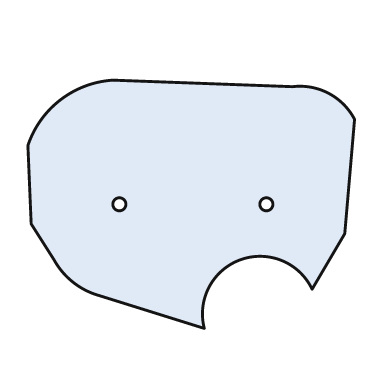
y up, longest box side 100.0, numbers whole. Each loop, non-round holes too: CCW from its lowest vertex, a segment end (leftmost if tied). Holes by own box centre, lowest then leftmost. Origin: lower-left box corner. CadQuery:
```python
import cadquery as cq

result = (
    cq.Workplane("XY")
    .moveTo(54.0, 0.0)
    .threePointArc((65.0, 21.0), (87.0, 12.0))
    .lineTo(97.0, 29.0)
    .lineTo(100.0, 64.0)
    .threePointArc((92.0, 72.0), (81.0, 74.0))
    .lineTo(26.0, 76.0)
    .threePointArc((10.0, 70.0), (0.0, 56.0))
    .lineTo(1.0, 32.0)
    .lineTo(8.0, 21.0)
    .threePointArc((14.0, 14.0), (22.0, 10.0))
    .close()
    .moveTo(28.0, 38.0)
    .circle(2.0)
    .moveTo(73.0, 38.0)
    .circle(2.0)
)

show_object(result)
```